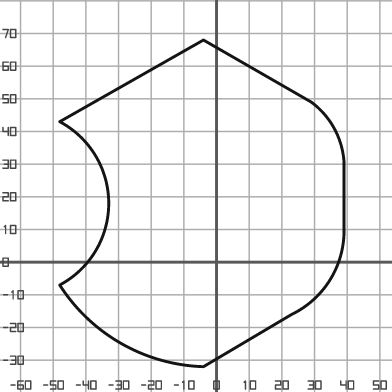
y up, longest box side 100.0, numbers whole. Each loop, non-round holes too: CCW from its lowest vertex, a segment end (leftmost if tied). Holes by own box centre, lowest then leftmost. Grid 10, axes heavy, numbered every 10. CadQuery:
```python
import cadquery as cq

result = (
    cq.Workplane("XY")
    .moveTo(-4.0, -32.0)
    .lineTo(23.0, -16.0)
    .threePointArc((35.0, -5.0), (39.0, 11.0))
    .lineTo(39.0, 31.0)
    .threePointArc((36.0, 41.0), (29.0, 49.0))
    .lineTo(-4.0, 68.0)
    .lineTo(-48.0, 43.0)
    .threePointArc((-33.0, 18.0), (-48.0, -7.0))
    .threePointArc((-29.0, -25.0), (-4.0, -32.0))
    .close()
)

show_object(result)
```